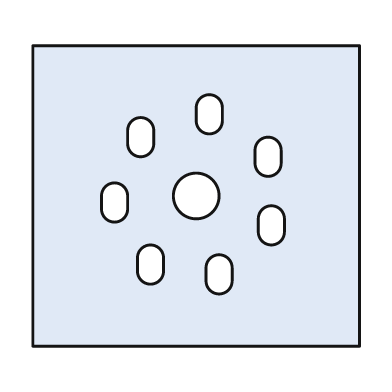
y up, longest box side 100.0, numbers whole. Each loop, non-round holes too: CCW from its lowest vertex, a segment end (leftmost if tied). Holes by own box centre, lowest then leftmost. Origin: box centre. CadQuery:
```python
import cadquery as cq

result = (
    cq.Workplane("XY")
    .moveTo(-50.0, -46.0)
    .lineTo(50.0, -46.0)
    .lineTo(50.0, 46.0)
    .lineTo(-50.0, 46.0)
    .close()
    .moveTo(3.0, -26.0)
    .threePointArc((7.0, -30.0), (11.0, -26.0))
    .lineTo(11.0, -22.0)
    .threePointArc((7.0, -18.0), (3.0, -22.0))
    .close()
    .moveTo(-18.0, -23.0)
    .threePointArc((-14.0, -27.0), (-10.0, -23.0))
    .lineTo(-10.0, -19.0)
    .threePointArc((-14.0, -15.0), (-18.0, -19.0))
    .close()
    .moveTo(19.0, -11.0)
    .threePointArc((23.0, -15.0), (27.0, -11.0))
    .lineTo(27.0, -7.0)
    .threePointArc((23.0, -3.0), (19.0, -7.0))
    .close()
    .moveTo(-29.0, -4.0)
    .threePointArc((-25.0, -8.0), (-21.0, -4.0))
    .lineTo(-21.0, 0.0)
    .threePointArc((-25.0, 4.0), (-29.0, 0.0))
    .close()
    .moveTo(0.0, 0.0)
    .circle(7.0)
    .moveTo(18.0, 10.0)
    .threePointArc((22.0, 6.0), (26.0, 10.0))
    .lineTo(26.0, 14.0)
    .threePointArc((22.0, 18.0), (18.0, 14.0))
    .close()
    .moveTo(-21.0, 16.0)
    .threePointArc((-17.0, 12.0), (-13.0, 16.0))
    .lineTo(-13.0, 20.0)
    .threePointArc((-17.0, 24.0), (-21.0, 20.0))
    .close()
    .moveTo(0.0, 23.0)
    .threePointArc((4.0, 19.0), (8.0, 23.0))
    .lineTo(8.0, 27.0)
    .threePointArc((4.0, 31.0), (0.0, 27.0))
    .close()
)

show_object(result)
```